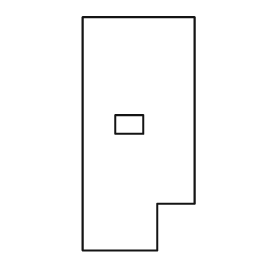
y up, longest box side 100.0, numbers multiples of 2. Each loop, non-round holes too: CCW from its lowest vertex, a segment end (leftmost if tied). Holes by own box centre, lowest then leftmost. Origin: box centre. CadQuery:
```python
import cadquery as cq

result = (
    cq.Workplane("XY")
    .moveTo(-24.0, -50.0)
    .lineTo(8.0, -50.0)
    .lineTo(8.0, -30.0)
    .lineTo(24.0, -30.0)
    .lineTo(24.0, 50.0)
    .lineTo(-24.0, 50.0)
    .close()
    .moveTo(-10.0, 0.0)
    .lineTo(2.0, 0.0)
    .lineTo(2.0, 8.0)
    .lineTo(-10.0, 8.0)
    .close()
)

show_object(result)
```